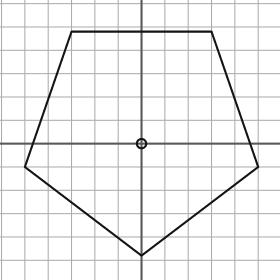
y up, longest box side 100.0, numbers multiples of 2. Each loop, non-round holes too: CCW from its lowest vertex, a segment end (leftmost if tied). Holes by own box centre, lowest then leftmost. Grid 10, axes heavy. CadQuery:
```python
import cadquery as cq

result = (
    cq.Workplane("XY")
    .moveTo(0.0, -48.0)
    .lineTo(50.0, -10.0)
    .lineTo(30.0, 48.0)
    .lineTo(-30.0, 48.0)
    .lineTo(-50.0, -10.0)
    .close()
    .moveTo(0.0, 0.0)
    .circle(2.0)
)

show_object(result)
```